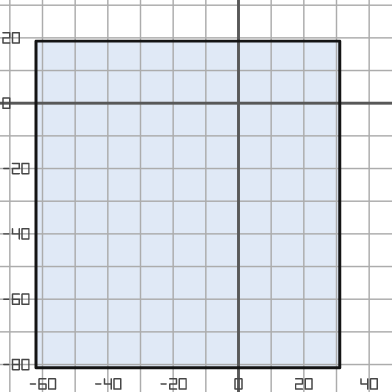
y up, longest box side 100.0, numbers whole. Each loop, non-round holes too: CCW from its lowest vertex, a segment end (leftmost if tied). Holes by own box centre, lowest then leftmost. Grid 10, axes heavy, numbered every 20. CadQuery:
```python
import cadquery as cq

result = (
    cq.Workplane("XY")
    .moveTo(-62.0, -81.0)
    .lineTo(31.0, -81.0)
    .lineTo(31.0, 19.0)
    .lineTo(-62.0, 19.0)
    .close()
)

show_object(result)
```